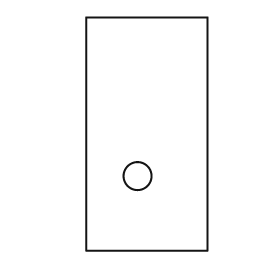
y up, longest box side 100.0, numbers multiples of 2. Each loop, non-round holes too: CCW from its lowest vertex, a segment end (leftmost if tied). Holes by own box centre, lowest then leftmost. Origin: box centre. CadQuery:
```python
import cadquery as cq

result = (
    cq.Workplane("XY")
    .moveTo(-26.0, -50.0)
    .lineTo(26.0, -50.0)
    .lineTo(26.0, 50.0)
    .lineTo(-26.0, 50.0)
    .close()
    .moveTo(-4.0, -18.0)
    .circle(6.0)
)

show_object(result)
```